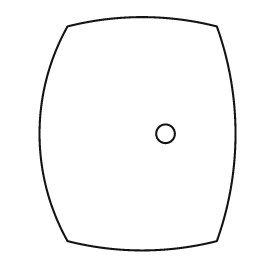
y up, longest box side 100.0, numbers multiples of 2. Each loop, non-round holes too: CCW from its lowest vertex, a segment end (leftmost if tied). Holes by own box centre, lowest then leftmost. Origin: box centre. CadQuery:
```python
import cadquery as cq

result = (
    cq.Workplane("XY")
    .moveTo(-30.0, -46.0)
    .threePointArc((2.0, -50.0), (34.0, -46.0))
    .threePointArc((42.0, 0.0), (34.0, 46.0))
    .threePointArc((2.0, 50.0), (-30.0, 46.0))
    .threePointArc((-42.0, 0.0), (-30.0, -46.0))
    .close()
    .moveTo(12.0, 0.0)
    .circle(4.0)
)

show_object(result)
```